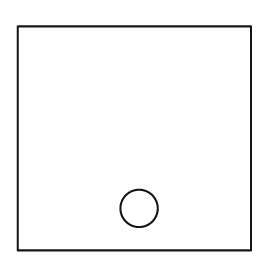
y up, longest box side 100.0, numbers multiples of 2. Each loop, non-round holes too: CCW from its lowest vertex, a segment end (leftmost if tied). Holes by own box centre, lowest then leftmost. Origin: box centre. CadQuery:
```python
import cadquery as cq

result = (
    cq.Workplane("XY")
    .moveTo(-50.0, -48.0)
    .lineTo(50.0, -48.0)
    .lineTo(50.0, 48.0)
    .lineTo(-50.0, 48.0)
    .close()
    .moveTo(2.0, -30.0)
    .circle(8.0)
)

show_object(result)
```